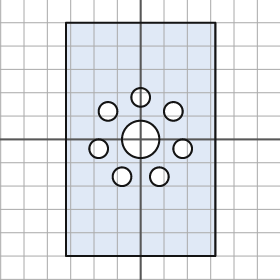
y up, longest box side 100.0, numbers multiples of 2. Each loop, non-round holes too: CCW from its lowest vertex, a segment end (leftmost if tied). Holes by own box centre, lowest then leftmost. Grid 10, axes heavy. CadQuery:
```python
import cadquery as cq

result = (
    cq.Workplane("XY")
    .moveTo(-32.0, -50.0)
    .lineTo(32.0, -50.0)
    .lineTo(32.0, 50.0)
    .lineTo(-32.0, 50.0)
    .close()
    .moveTo(-8.0, -16.0)
    .circle(4.0)
    .moveTo(8.0, -16.0)
    .circle(4.0)
    .moveTo(-18.0, -4.0)
    .circle(4.0)
    .moveTo(18.0, -4.0)
    .circle(4.0)
    .moveTo(0.0, 0.0)
    .circle(8.0)
    .moveTo(-14.0, 12.0)
    .circle(4.0)
    .moveTo(14.0, 12.0)
    .circle(4.0)
    .moveTo(0.0, 18.0)
    .circle(4.0)
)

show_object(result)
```